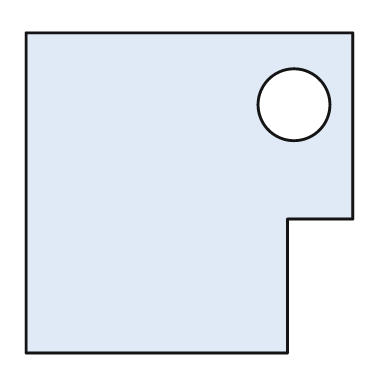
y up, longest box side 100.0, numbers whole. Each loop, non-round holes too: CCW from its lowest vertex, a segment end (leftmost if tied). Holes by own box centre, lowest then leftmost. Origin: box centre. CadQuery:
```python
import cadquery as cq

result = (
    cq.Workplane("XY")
    .moveTo(-50.0, -49.0)
    .lineTo(30.0, -49.0)
    .lineTo(30.0, -8.0)
    .lineTo(50.0, -8.0)
    .lineTo(50.0, 49.0)
    .lineTo(-50.0, 49.0)
    .close()
    .moveTo(32.0, 27.0)
    .circle(11.0)
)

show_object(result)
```